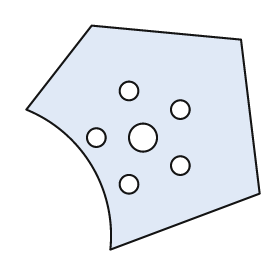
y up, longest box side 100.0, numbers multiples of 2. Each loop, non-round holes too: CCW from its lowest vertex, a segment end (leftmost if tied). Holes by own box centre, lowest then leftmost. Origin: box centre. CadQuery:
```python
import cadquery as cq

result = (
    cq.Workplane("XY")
    .moveTo(-14.0, -48.0)
    .lineTo(50.0, -24.0)
    .lineTo(42.0, 42.0)
    .lineTo(-22.0, 48.0)
    .lineTo(-50.0, 12.0)
    .threePointArc((-22.0, -12.0), (-14.0, -48.0))
    .close()
    .moveTo(-6.0, -20.0)
    .circle(4.0)
    .moveTo(16.0, -12.0)
    .circle(4.0)
    .moveTo(-20.0, 0.0)
    .circle(4.0)
    .moveTo(0.0, 0.0)
    .circle(6.0)
    .moveTo(16.0, 12.0)
    .circle(4.0)
    .moveTo(-6.0, 20.0)
    .circle(4.0)
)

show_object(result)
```